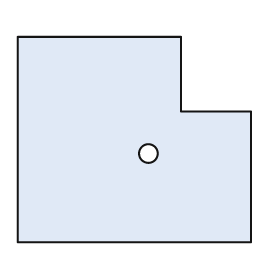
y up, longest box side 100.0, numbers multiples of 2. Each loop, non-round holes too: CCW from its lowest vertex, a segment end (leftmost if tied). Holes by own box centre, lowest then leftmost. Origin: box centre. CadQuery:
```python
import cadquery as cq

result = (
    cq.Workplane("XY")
    .moveTo(-50.0, -44.0)
    .lineTo(50.0, -44.0)
    .lineTo(50.0, 12.0)
    .lineTo(20.0, 12.0)
    .lineTo(20.0, 44.0)
    .lineTo(-50.0, 44.0)
    .close()
    .moveTo(6.0, -6.0)
    .circle(4.0)
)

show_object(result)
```